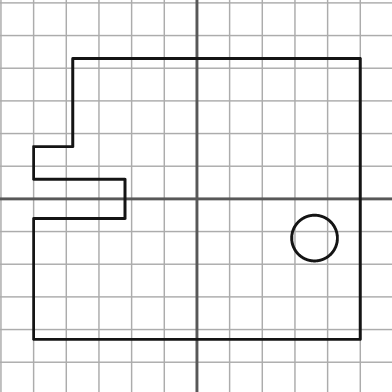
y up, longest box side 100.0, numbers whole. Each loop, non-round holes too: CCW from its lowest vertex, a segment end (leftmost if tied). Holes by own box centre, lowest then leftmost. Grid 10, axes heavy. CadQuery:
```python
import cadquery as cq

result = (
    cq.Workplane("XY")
    .moveTo(-50.0, -43.0)
    .lineTo(50.0, -43.0)
    .lineTo(50.0, 43.0)
    .lineTo(-38.0, 43.0)
    .lineTo(-38.0, 16.0)
    .lineTo(-50.0, 16.0)
    .lineTo(-50.0, 6.0)
    .lineTo(-22.0, 6.0)
    .lineTo(-22.0, -6.0)
    .lineTo(-50.0, -6.0)
    .close()
    .moveTo(36.0, -12.0)
    .circle(7.0)
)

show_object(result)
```